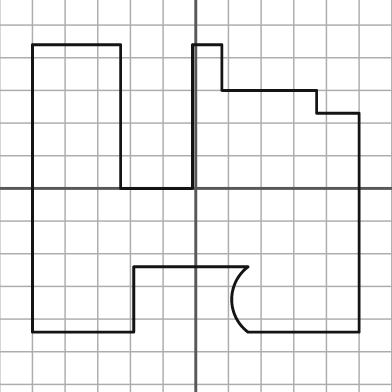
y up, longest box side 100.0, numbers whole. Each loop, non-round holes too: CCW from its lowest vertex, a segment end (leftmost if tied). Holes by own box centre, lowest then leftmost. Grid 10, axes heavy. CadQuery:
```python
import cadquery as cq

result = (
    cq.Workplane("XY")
    .moveTo(-50.0, -44.0)
    .lineTo(-19.0, -44.0)
    .lineTo(-19.0, -24.0)
    .lineTo(16.0, -24.0)
    .threePointArc((11.0, -34.0), (16.0, -44.0))
    .lineTo(50.0, -44.0)
    .lineTo(50.0, 23.0)
    .lineTo(37.0, 23.0)
    .lineTo(37.0, 30.0)
    .lineTo(8.0, 30.0)
    .lineTo(8.0, 44.0)
    .lineTo(-1.0, 44.0)
    .lineTo(-1.0, 0.0)
    .lineTo(-23.0, 0.0)
    .lineTo(-23.0, 44.0)
    .lineTo(-50.0, 44.0)
    .close()
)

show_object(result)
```